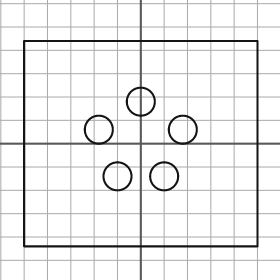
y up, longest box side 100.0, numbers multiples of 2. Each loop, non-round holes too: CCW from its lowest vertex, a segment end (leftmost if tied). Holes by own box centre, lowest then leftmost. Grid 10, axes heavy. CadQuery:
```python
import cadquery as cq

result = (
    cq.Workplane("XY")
    .moveTo(-50.0, -44.0)
    .lineTo(50.0, -44.0)
    .lineTo(50.0, 44.0)
    .lineTo(-50.0, 44.0)
    .close()
    .moveTo(-10.0, -14.0)
    .circle(6.0)
    .moveTo(10.0, -14.0)
    .circle(6.0)
    .moveTo(-18.0, 6.0)
    .circle(6.0)
    .moveTo(18.0, 6.0)
    .circle(6.0)
    .moveTo(0.0, 18.0)
    .circle(6.0)
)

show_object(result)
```